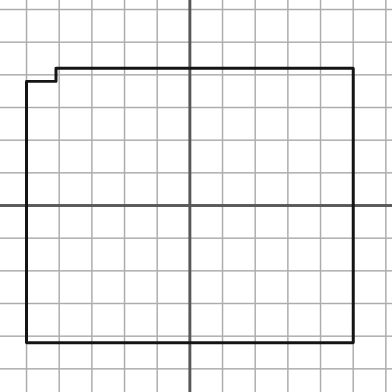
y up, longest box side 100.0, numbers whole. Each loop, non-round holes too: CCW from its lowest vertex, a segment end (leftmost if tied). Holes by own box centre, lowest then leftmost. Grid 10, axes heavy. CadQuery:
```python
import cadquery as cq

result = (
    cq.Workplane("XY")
    .moveTo(-50.0, -42.0)
    .lineTo(50.0, -42.0)
    .lineTo(50.0, 42.0)
    .lineTo(-41.0, 42.0)
    .lineTo(-41.0, 38.0)
    .lineTo(-50.0, 38.0)
    .close()
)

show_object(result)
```